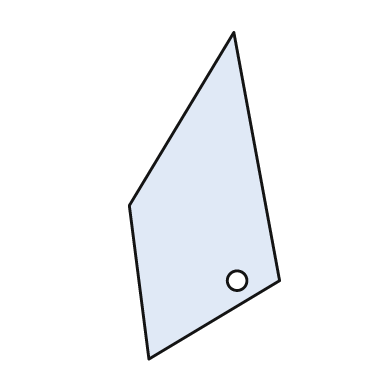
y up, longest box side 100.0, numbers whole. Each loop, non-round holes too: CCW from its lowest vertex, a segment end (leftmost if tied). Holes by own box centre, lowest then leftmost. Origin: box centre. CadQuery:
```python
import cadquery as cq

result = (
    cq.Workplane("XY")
    .moveTo(-17.0, -50.0)
    .lineTo(23.0, -26.0)
    .lineTo(9.0, 50.0)
    .lineTo(-23.0, -3.0)
    .close()
    .moveTo(10.0, -26.0)
    .circle(3.0)
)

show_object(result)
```